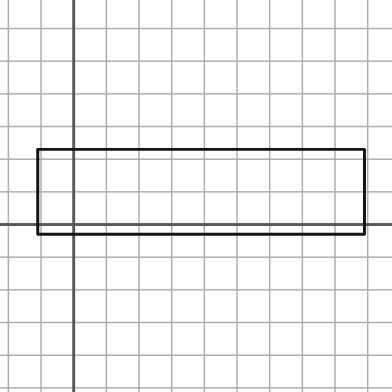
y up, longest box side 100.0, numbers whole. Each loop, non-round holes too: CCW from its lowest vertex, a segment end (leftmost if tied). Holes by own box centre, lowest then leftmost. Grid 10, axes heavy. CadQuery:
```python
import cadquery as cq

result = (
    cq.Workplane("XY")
    .moveTo(-11.0, -3.0)
    .lineTo(89.0, -3.0)
    .lineTo(89.0, 23.0)
    .lineTo(-11.0, 23.0)
    .close()
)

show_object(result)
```